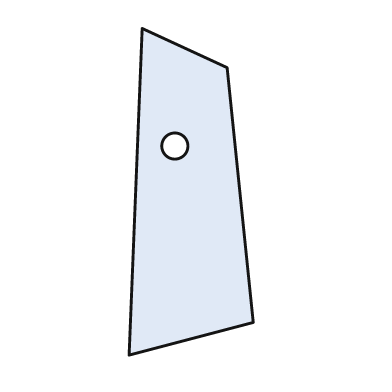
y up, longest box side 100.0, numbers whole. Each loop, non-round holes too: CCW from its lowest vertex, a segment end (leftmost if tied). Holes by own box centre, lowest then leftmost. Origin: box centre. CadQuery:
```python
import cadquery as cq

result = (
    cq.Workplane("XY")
    .moveTo(-19.0, -50.0)
    .lineTo(19.0, -40.0)
    .lineTo(11.0, 38.0)
    .lineTo(-15.0, 50.0)
    .close()
    .moveTo(-5.0, 14.0)
    .circle(4.0)
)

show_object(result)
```